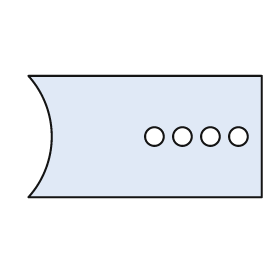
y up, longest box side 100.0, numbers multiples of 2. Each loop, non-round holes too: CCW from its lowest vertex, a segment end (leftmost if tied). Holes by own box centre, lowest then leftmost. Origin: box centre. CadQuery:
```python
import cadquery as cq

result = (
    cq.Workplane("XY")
    .moveTo(-50.0, -26.0)
    .lineTo(50.0, -26.0)
    .lineTo(50.0, 26.0)
    .lineTo(-50.0, 26.0)
    .threePointArc((-40.0, 0.0), (-50.0, -26.0))
    .close()
    .moveTo(4.0, 0.0)
    .circle(4.0)
    .moveTo(16.0, 0.0)
    .circle(4.0)
    .moveTo(28.0, 0.0)
    .circle(4.0)
    .moveTo(40.0, 0.0)
    .circle(4.0)
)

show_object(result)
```